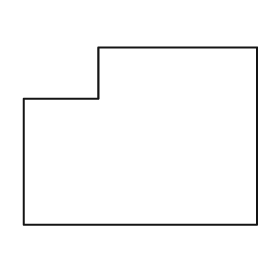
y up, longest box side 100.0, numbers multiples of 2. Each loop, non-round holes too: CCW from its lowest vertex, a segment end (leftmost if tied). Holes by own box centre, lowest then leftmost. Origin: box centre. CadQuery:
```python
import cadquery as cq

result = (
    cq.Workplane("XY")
    .moveTo(-50.0, -38.0)
    .lineTo(50.0, -38.0)
    .lineTo(50.0, 38.0)
    .lineTo(-18.0, 38.0)
    .lineTo(-18.0, 16.0)
    .lineTo(-50.0, 16.0)
    .close()
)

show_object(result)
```